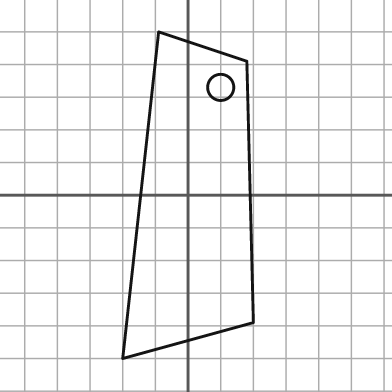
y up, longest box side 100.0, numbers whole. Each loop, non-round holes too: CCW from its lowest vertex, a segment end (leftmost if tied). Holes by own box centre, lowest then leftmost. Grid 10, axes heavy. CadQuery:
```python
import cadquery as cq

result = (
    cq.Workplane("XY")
    .moveTo(-20.0, -50.0)
    .lineTo(20.0, -39.0)
    .lineTo(18.0, 41.0)
    .lineTo(-9.0, 50.0)
    .close()
    .moveTo(10.0, 33.0)
    .circle(4.0)
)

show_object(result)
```